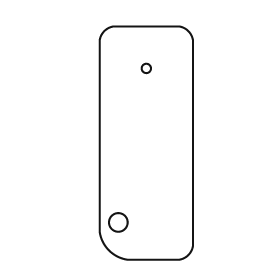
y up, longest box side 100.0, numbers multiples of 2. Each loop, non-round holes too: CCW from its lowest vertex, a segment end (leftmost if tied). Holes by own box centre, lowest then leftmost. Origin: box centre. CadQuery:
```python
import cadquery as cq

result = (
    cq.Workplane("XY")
    .moveTo(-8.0, -50.0)
    .lineTo(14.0, -50.0)
    .threePointArc((18.0, -48.0), (20.0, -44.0))
    .lineTo(20.0, 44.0)
    .threePointArc((18.0, 48.0), (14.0, 50.0))
    .lineTo(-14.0, 50.0)
    .threePointArc((-18.0, 48.0), (-20.0, 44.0))
    .lineTo(-20.0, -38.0)
    .threePointArc((-16.0, -46.0), (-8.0, -50.0))
    .close()
    .moveTo(-12.0, -34.0)
    .circle(4.0)
    .moveTo(0.0, 32.0)
    .circle(2.0)
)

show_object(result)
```